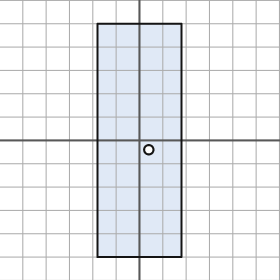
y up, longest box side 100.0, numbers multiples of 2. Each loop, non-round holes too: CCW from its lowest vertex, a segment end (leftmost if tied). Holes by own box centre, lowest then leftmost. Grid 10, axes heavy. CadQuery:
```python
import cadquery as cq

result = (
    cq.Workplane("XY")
    .moveTo(-18.0, -50.0)
    .lineTo(18.0, -50.0)
    .lineTo(18.0, 50.0)
    .lineTo(-18.0, 50.0)
    .close()
    .moveTo(4.0, -4.0)
    .circle(2.0)
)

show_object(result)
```